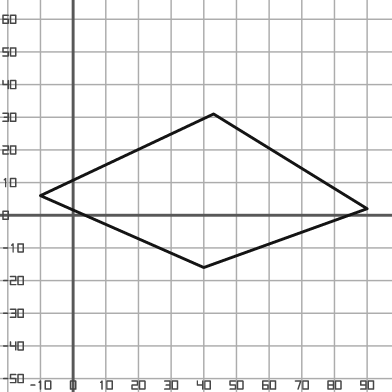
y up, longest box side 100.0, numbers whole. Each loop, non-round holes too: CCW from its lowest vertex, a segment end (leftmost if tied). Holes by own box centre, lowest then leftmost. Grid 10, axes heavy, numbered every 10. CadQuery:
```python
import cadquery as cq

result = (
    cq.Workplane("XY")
    .moveTo(40.0, -16.0)
    .lineTo(90.0, 2.0)
    .lineTo(43.0, 31.0)
    .lineTo(-10.0, 6.0)
    .close()
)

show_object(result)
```